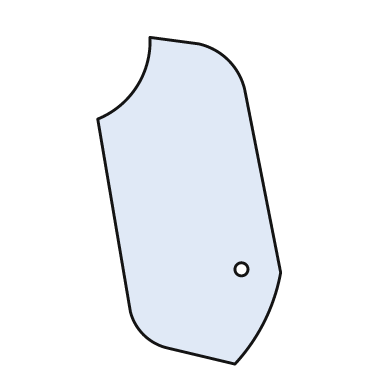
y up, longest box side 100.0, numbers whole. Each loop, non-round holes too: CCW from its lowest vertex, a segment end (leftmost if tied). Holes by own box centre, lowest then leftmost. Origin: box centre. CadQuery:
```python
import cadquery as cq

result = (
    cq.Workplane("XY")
    .moveTo(14.0, -50.0)
    .threePointArc((23.0, -37.0), (28.0, -22.0))
    .lineTo(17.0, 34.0)
    .threePointArc((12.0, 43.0), (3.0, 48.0))
    .lineTo(-12.0, 50.0)
    .threePointArc((-16.0, 35.0), (-28.0, 25.0))
    .lineTo(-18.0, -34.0)
    .threePointArc((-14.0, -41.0), (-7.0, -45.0))
    .close()
    .moveTo(16.0, -21.0)
    .circle(2.0)
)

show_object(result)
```